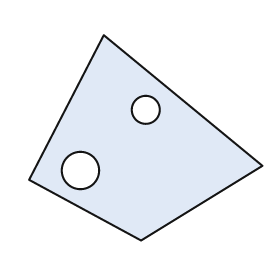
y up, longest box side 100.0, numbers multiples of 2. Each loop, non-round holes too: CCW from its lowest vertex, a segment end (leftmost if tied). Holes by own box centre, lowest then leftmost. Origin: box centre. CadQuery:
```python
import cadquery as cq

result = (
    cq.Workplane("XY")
    .moveTo(-2.0, -44.0)
    .lineTo(50.0, -12.0)
    .lineTo(-18.0, 44.0)
    .lineTo(-50.0, -18.0)
    .close()
    .moveTo(-28.0, -14.0)
    .circle(8.0)
    .moveTo(0.0, 12.0)
    .circle(6.0)
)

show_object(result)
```